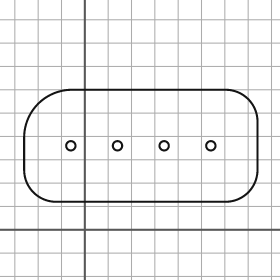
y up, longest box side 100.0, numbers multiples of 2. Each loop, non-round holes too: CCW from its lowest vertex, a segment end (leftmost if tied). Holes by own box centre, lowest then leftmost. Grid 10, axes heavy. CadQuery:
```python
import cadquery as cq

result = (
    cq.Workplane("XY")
    .moveTo(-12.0, 12.0)
    .lineTo(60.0, 12.0)
    .threePointArc((70.0, 16.0), (74.0, 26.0))
    .lineTo(74.0, 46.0)
    .threePointArc((70.0, 56.0), (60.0, 60.0))
    .lineTo(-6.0, 60.0)
    .threePointArc((-20.0, 54.0), (-26.0, 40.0))
    .lineTo(-26.0, 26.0)
    .threePointArc((-22.0, 16.0), (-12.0, 12.0))
    .close()
    .moveTo(-6.0, 36.0)
    .circle(2.0)
    .moveTo(14.0, 36.0)
    .circle(2.0)
    .moveTo(34.0, 36.0)
    .circle(2.0)
    .moveTo(54.0, 36.0)
    .circle(2.0)
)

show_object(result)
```